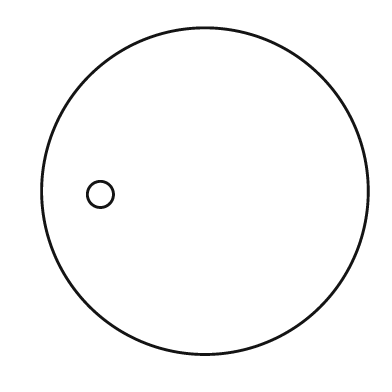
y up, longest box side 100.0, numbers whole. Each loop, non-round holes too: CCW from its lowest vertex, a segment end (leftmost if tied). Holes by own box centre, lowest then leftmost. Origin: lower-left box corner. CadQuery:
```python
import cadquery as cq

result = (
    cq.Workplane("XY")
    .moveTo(50.0, 50.0)
    .circle(50.0)
    .moveTo(18.0, 49.0)
    .circle(4.0)
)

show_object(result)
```